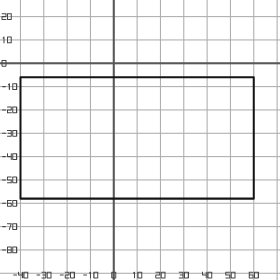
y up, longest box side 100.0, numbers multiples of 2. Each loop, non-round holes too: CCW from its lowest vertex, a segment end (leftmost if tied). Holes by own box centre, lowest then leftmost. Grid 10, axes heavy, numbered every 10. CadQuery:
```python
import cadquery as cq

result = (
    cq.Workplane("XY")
    .moveTo(-40.0, -58.0)
    .lineTo(60.0, -58.0)
    .lineTo(60.0, -6.0)
    .lineTo(-40.0, -6.0)
    .close()
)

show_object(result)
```